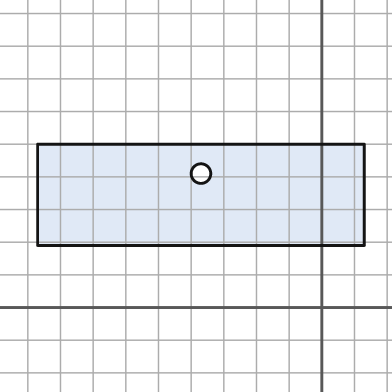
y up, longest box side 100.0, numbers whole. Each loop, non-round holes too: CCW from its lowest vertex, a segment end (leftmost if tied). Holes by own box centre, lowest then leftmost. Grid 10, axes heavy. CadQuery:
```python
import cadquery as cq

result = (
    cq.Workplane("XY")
    .moveTo(-87.0, 19.0)
    .lineTo(13.0, 19.0)
    .lineTo(13.0, 50.0)
    .lineTo(-87.0, 50.0)
    .close()
    .moveTo(-37.0, 41.0)
    .circle(3.0)
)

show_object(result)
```